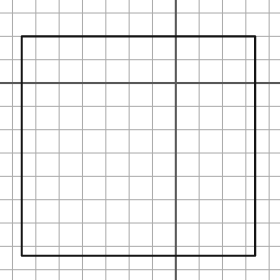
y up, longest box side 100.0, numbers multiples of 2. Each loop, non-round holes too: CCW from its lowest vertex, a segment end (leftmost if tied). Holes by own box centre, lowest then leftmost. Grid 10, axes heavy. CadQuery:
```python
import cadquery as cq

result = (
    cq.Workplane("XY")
    .moveTo(-66.0, -74.0)
    .lineTo(34.0, -74.0)
    .lineTo(34.0, 20.0)
    .lineTo(-66.0, 20.0)
    .close()
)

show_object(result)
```